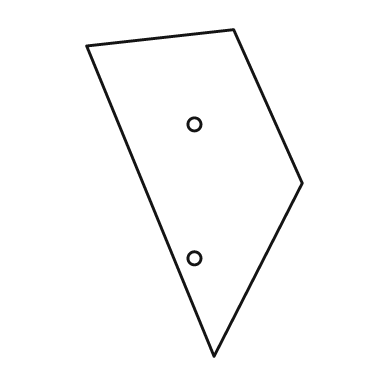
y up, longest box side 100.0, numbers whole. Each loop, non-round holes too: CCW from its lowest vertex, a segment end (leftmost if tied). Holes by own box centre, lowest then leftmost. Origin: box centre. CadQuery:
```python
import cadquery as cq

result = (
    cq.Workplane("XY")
    .moveTo(6.0, -50.0)
    .lineTo(33.0, 3.0)
    .lineTo(12.0, 50.0)
    .lineTo(-33.0, 45.0)
    .close()
    .moveTo(0.0, -20.0)
    .circle(2.0)
    .moveTo(0.0, 21.0)
    .circle(2.0)
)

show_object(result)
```